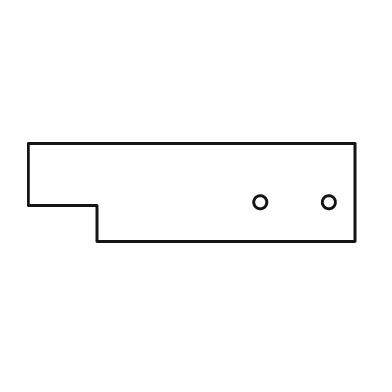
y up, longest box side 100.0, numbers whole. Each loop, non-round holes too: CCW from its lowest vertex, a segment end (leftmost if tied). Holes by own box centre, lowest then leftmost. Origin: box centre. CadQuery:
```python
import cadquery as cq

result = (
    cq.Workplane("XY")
    .moveTo(-29.0, -15.0)
    .lineTo(50.0, -15.0)
    .lineTo(50.0, 15.0)
    .lineTo(-50.0, 15.0)
    .lineTo(-50.0, -4.0)
    .lineTo(-29.0, -4.0)
    .close()
    .moveTo(21.0, -3.0)
    .circle(2.0)
    .moveTo(42.0, -3.0)
    .circle(2.0)
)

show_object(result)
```